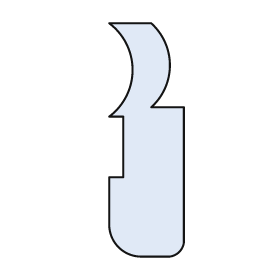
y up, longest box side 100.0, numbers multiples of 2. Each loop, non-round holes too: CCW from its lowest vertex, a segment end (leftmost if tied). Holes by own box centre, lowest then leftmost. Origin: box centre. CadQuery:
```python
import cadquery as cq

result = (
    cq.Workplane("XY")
    .moveTo(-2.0, -50.0)
    .lineTo(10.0, -50.0)
    .threePointArc((14.0, -48.0), (16.0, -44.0))
    .lineTo(16.0, 14.0)
    .lineTo(2.0, 14.0)
    .threePointArc((10.0, 32.0), (2.0, 50.0))
    .lineTo(-16.0, 50.0)
    .threePointArc((-6.0, 30.0), (-16.0, 10.0))
    .lineTo(-10.0, 10.0)
    .lineTo(-10.0, -16.0)
    .lineTo(-16.0, -16.0)
    .lineTo(-16.0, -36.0)
    .threePointArc((-12.0, -46.0), (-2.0, -50.0))
    .close()
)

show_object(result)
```